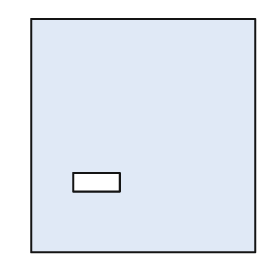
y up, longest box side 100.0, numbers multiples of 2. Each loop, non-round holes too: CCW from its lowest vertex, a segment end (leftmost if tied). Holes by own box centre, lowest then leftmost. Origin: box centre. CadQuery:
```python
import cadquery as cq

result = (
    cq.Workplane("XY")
    .moveTo(-48.0, -50.0)
    .lineTo(48.0, -50.0)
    .lineTo(48.0, 50.0)
    .lineTo(-48.0, 50.0)
    .close()
    .moveTo(-30.0, -24.0)
    .lineTo(-10.0, -24.0)
    .lineTo(-10.0, -16.0)
    .lineTo(-30.0, -16.0)
    .close()
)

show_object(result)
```